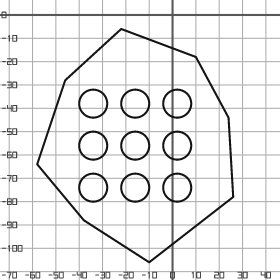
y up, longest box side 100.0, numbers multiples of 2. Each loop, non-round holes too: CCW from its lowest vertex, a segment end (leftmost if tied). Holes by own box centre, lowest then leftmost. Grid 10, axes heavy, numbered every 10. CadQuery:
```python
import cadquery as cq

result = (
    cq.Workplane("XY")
    .moveTo(-10.0, -106.0)
    .lineTo(26.0, -78.0)
    .lineTo(24.0, -44.0)
    .lineTo(10.0, -18.0)
    .lineTo(-22.0, -6.0)
    .lineTo(-46.0, -28.0)
    .lineTo(-58.0, -64.0)
    .lineTo(-38.0, -88.0)
    .close()
    .moveTo(-34.0, -74.0)
    .circle(6.0)
    .moveTo(-16.0, -74.0)
    .circle(6.0)
    .moveTo(2.0, -74.0)
    .circle(6.0)
    .moveTo(-34.0, -56.0)
    .circle(6.0)
    .moveTo(-16.0, -56.0)
    .circle(6.0)
    .moveTo(2.0, -56.0)
    .circle(6.0)
    .moveTo(-34.0, -38.0)
    .circle(6.0)
    .moveTo(-16.0, -38.0)
    .circle(6.0)
    .moveTo(2.0, -38.0)
    .circle(6.0)
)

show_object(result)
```